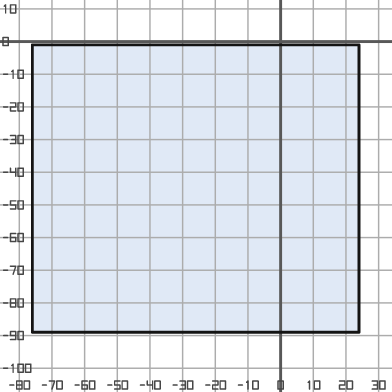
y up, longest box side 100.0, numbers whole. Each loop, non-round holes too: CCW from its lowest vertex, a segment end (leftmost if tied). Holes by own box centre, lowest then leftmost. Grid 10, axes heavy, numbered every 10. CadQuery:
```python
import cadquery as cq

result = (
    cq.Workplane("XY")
    .moveTo(-76.0, -89.0)
    .lineTo(24.0, -89.0)
    .lineTo(24.0, -1.0)
    .lineTo(-76.0, -1.0)
    .close()
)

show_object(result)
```